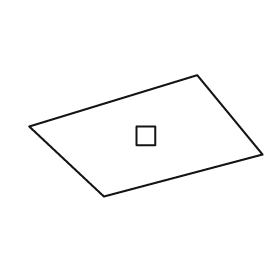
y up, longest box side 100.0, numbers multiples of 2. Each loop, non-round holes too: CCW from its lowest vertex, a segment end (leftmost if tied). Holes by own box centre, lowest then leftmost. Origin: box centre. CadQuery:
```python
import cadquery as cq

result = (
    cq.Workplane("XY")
    .moveTo(-18.0, -26.0)
    .lineTo(50.0, -8.0)
    .lineTo(22.0, 26.0)
    .lineTo(-50.0, 4.0)
    .close()
    .moveTo(-4.0, -4.0)
    .lineTo(4.0, -4.0)
    .lineTo(4.0, 4.0)
    .lineTo(-4.0, 4.0)
    .close()
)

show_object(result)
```